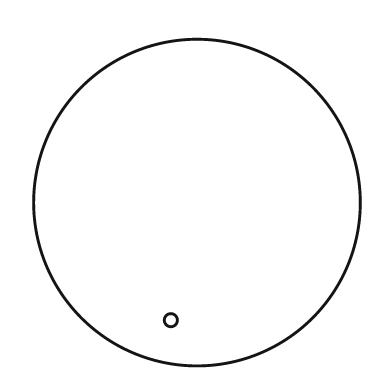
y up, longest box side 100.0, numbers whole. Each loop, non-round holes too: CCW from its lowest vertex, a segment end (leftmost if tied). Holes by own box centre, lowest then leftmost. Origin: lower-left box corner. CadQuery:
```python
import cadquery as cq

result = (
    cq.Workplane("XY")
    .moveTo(50.0, 50.0)
    .circle(50.0)
    .moveTo(42.0, 14.0)
    .circle(2.0)
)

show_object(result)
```